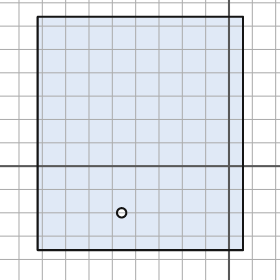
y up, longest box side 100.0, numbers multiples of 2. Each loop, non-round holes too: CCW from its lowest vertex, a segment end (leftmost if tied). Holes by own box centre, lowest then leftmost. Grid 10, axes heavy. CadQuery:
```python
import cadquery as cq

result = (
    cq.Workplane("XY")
    .moveTo(-82.0, -36.0)
    .lineTo(6.0, -36.0)
    .lineTo(6.0, 64.0)
    .lineTo(-82.0, 64.0)
    .close()
    .moveTo(-46.0, -20.0)
    .circle(2.0)
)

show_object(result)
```